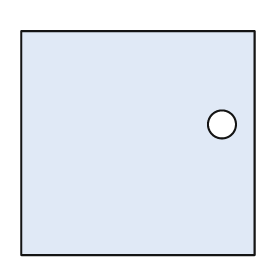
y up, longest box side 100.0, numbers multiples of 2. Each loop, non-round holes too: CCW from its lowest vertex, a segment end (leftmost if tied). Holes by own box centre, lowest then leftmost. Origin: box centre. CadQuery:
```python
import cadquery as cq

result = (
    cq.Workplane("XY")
    .moveTo(-50.0, -48.0)
    .lineTo(50.0, -48.0)
    .lineTo(50.0, 48.0)
    .lineTo(-50.0, 48.0)
    .close()
    .moveTo(36.0, 8.0)
    .circle(6.0)
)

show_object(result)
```